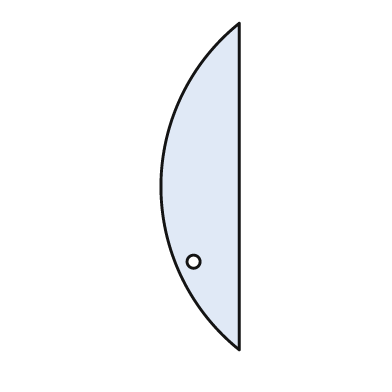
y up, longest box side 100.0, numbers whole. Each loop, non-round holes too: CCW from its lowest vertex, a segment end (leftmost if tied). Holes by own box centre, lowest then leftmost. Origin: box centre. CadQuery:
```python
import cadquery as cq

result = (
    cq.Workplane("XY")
    .moveTo(12.0, -50.0)
    .lineTo(12.0, 50.0)
    .threePointArc((-12.0, 0.0), (12.0, -50.0))
    .close()
    .moveTo(-2.0, -23.0)
    .circle(2.0)
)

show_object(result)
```